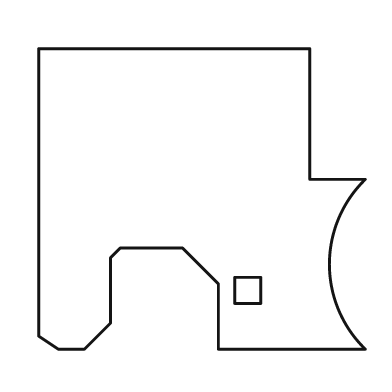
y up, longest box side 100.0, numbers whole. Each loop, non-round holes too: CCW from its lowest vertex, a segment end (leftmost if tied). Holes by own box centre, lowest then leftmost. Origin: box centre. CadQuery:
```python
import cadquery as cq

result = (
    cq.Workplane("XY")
    .moveTo(-44.0, -46.0)
    .lineTo(-36.0, -46.0)
    .lineTo(-28.0, -38.0)
    .lineTo(-28.0, -18.0)
    .lineTo(-25.0, -15.0)
    .lineTo(-6.0, -15.0)
    .lineTo(5.0, -26.0)
    .lineTo(5.0, -46.0)
    .lineTo(50.0, -46.0)
    .threePointArc((39.0, -20.0), (50.0, 6.0))
    .lineTo(33.0, 6.0)
    .lineTo(33.0, 46.0)
    .lineTo(-50.0, 46.0)
    .lineTo(-50.0, -42.0)
    .close()
    .moveTo(10.0, -32.0)
    .lineTo(18.0, -32.0)
    .lineTo(18.0, -24.0)
    .lineTo(10.0, -24.0)
    .close()
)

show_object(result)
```